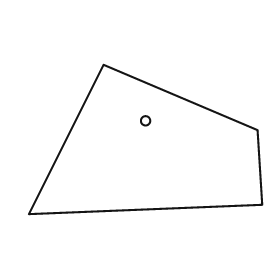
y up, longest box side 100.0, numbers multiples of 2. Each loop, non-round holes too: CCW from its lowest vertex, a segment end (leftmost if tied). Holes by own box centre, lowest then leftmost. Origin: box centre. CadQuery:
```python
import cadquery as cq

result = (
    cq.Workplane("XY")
    .moveTo(-50.0, -32.0)
    .lineTo(50.0, -28.0)
    .lineTo(48.0, 4.0)
    .lineTo(-18.0, 32.0)
    .close()
    .moveTo(0.0, 8.0)
    .circle(2.0)
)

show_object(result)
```